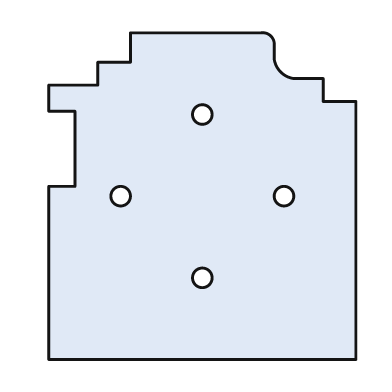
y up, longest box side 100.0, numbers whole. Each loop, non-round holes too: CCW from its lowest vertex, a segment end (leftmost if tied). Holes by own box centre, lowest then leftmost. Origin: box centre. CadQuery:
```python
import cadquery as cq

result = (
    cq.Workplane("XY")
    .moveTo(-47.0, -50.0)
    .lineTo(47.0, -50.0)
    .lineTo(47.0, 29.0)
    .lineTo(37.0, 29.0)
    .lineTo(37.0, 36.0)
    .lineTo(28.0, 36.0)
    .threePointArc((24.0, 38.0), (22.0, 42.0))
    .lineTo(22.0, 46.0)
    .threePointArc((21.0, 49.0), (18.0, 50.0))
    .lineTo(-22.0, 50.0)
    .lineTo(-22.0, 41.0)
    .lineTo(-32.0, 41.0)
    .lineTo(-32.0, 34.0)
    .lineTo(-47.0, 34.0)
    .lineTo(-47.0, 26.0)
    .lineTo(-39.0, 26.0)
    .lineTo(-39.0, 3.0)
    .lineTo(-47.0, 3.0)
    .close()
    .moveTo(0.0, -25.0)
    .circle(3.0)
    .moveTo(-25.0, 0.0)
    .circle(3.0)
    .moveTo(25.0, 0.0)
    .circle(3.0)
    .moveTo(0.0, 25.0)
    .circle(3.0)
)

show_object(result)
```